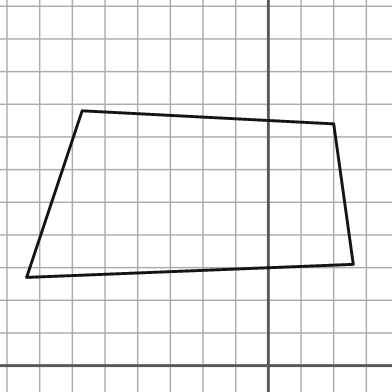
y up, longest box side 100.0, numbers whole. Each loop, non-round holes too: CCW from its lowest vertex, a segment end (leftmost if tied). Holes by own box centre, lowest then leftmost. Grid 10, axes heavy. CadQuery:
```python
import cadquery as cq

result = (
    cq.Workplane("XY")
    .moveTo(-74.0, 27.0)
    .lineTo(26.0, 31.0)
    .lineTo(20.0, 74.0)
    .lineTo(-57.0, 78.0)
    .close()
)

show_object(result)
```